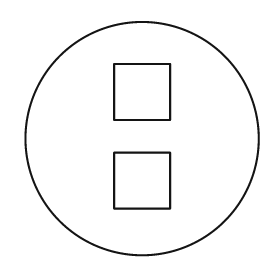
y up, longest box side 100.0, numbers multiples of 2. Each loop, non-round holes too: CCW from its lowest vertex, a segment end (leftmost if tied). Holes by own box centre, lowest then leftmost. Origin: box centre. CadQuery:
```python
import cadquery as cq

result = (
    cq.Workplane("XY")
    .moveTo(0.0, 0.0)
    .circle(50.0)
    .moveTo(-12.0, -30.0)
    .lineTo(12.0, -30.0)
    .lineTo(12.0, -6.0)
    .lineTo(-12.0, -6.0)
    .close()
    .moveTo(-12.0, 8.0)
    .lineTo(12.0, 8.0)
    .lineTo(12.0, 32.0)
    .lineTo(-12.0, 32.0)
    .close()
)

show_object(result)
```